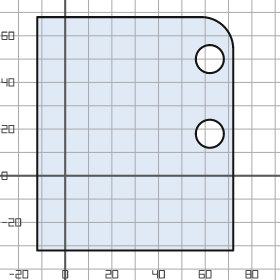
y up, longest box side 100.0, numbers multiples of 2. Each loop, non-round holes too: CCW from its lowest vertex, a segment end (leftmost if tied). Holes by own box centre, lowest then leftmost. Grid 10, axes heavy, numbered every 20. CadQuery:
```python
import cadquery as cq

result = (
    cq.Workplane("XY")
    .moveTo(-12.0, -32.0)
    .lineTo(72.0, -32.0)
    .lineTo(72.0, 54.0)
    .threePointArc((68.0, 64.0), (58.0, 68.0))
    .lineTo(-12.0, 68.0)
    .close()
    .moveTo(62.0, 18.0)
    .circle(6.0)
    .moveTo(62.0, 50.0)
    .circle(6.0)
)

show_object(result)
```